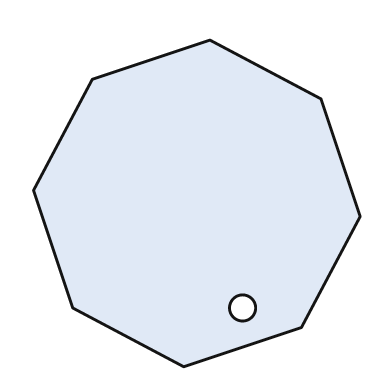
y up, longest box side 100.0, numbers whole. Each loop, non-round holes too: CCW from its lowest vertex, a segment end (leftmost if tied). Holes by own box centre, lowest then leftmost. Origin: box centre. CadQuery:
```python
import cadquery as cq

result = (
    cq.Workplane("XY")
    .moveTo(-4.0, -50.0)
    .lineTo(32.0, -38.0)
    .lineTo(50.0, -4.0)
    .lineTo(38.0, 32.0)
    .lineTo(4.0, 50.0)
    .lineTo(-32.0, 38.0)
    .lineTo(-50.0, 4.0)
    .lineTo(-38.0, -32.0)
    .close()
    .moveTo(14.0, -32.0)
    .circle(4.0)
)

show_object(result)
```